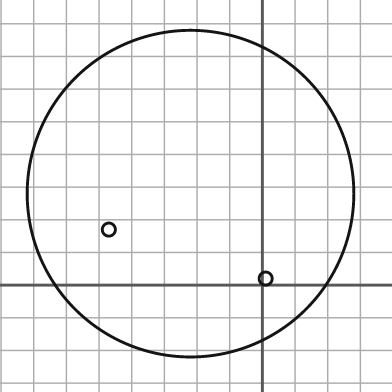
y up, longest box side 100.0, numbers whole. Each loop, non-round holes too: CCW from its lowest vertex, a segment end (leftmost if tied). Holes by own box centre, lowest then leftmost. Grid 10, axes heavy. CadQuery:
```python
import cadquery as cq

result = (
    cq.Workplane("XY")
    .moveTo(-22.0, 28.0)
    .circle(50.0)
    .moveTo(1.0, 2.0)
    .circle(2.0)
    .moveTo(-47.0, 17.0)
    .circle(2.0)
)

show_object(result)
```